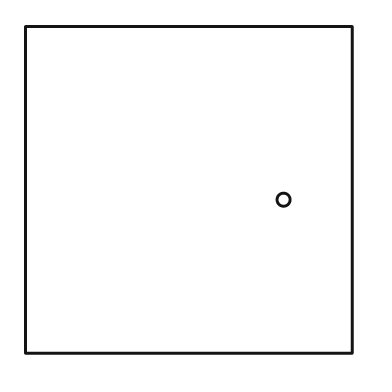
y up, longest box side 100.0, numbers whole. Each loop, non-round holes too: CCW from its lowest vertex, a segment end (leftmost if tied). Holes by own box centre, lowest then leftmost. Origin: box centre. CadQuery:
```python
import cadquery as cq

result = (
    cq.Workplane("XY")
    .moveTo(-50.0, -50.0)
    .lineTo(50.0, -50.0)
    .lineTo(50.0, 50.0)
    .lineTo(-50.0, 50.0)
    .close()
    .moveTo(29.0, -3.0)
    .circle(2.0)
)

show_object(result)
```